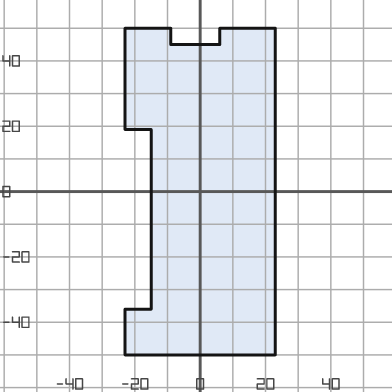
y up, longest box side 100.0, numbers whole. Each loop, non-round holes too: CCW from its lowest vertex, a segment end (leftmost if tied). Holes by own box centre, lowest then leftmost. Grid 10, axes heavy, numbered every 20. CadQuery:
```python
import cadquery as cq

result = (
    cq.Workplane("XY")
    .moveTo(-23.0, -50.0)
    .lineTo(23.0, -50.0)
    .lineTo(23.0, 50.0)
    .lineTo(6.0, 50.0)
    .lineTo(6.0, 45.0)
    .lineTo(-9.0, 45.0)
    .lineTo(-9.0, 50.0)
    .lineTo(-23.0, 50.0)
    .lineTo(-23.0, 19.0)
    .lineTo(-15.0, 19.0)
    .lineTo(-15.0, -36.0)
    .lineTo(-23.0, -36.0)
    .close()
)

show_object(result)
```